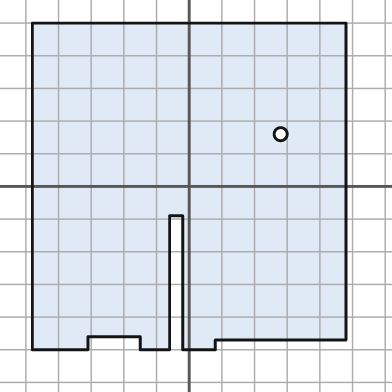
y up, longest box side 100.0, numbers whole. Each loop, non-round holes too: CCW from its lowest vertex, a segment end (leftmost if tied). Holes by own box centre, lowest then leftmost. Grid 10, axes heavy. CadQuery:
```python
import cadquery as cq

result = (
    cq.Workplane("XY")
    .moveTo(-48.0, -50.0)
    .lineTo(-31.0, -50.0)
    .lineTo(-31.0, -46.0)
    .lineTo(-15.0, -46.0)
    .lineTo(-15.0, -50.0)
    .lineTo(-6.0, -50.0)
    .lineTo(-6.0, -9.0)
    .lineTo(-2.0, -9.0)
    .lineTo(-2.0, -50.0)
    .lineTo(8.0, -50.0)
    .lineTo(8.0, -47.0)
    .lineTo(48.0, -47.0)
    .lineTo(48.0, 50.0)
    .lineTo(-48.0, 50.0)
    .close()
    .moveTo(28.0, 16.0)
    .circle(2.0)
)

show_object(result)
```